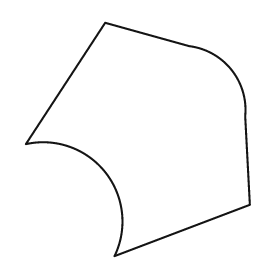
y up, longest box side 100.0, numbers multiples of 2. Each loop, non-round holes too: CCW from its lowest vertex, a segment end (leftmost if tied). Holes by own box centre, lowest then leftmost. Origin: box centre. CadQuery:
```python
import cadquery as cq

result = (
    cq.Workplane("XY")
    .moveTo(-10.0, -50.0)
    .lineTo(48.0, -28.0)
    .lineTo(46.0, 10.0)
    .threePointArc((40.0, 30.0), (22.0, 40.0))
    .lineTo(-14.0, 50.0)
    .lineTo(-48.0, -2.0)
    .threePointArc((-14.0, -14.0), (-10.0, -50.0))
    .close()
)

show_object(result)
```